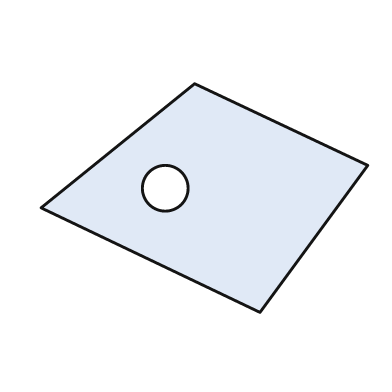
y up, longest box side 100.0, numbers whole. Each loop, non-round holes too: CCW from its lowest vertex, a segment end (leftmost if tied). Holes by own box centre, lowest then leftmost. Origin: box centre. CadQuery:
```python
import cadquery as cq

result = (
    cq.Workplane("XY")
    .moveTo(17.0, -35.0)
    .lineTo(50.0, 10.0)
    .lineTo(-3.0, 35.0)
    .lineTo(-50.0, -3.0)
    .close()
    .moveTo(-12.0, 3.0)
    .circle(7.0)
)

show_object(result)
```